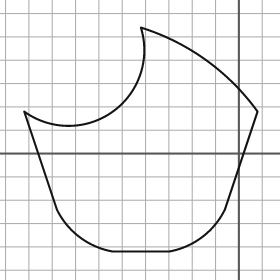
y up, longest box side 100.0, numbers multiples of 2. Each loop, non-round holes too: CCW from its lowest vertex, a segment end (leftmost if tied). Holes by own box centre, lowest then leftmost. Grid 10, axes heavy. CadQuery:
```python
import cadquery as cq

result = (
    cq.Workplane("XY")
    .moveTo(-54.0, -42.0)
    .lineTo(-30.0, -42.0)
    .threePointArc((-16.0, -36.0), (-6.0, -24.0))
    .lineTo(8.0, 18.0)
    .threePointArc((-14.0, 40.0), (-42.0, 54.0))
    .threePointArc((-54.0, 18.0), (-92.0, 18.0))
    .lineTo(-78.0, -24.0)
    .threePointArc((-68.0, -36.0), (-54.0, -42.0))
    .close()
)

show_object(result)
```